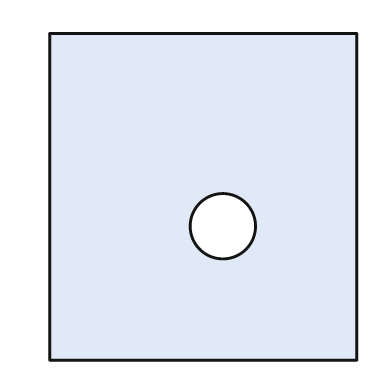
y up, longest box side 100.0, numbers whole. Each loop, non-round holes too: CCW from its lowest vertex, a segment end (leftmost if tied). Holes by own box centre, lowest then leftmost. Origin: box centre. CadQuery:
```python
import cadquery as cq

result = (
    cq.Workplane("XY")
    .moveTo(-47.0, -50.0)
    .lineTo(47.0, -50.0)
    .lineTo(47.0, 50.0)
    .lineTo(-47.0, 50.0)
    .close()
    .moveTo(6.0, -9.0)
    .circle(10.0)
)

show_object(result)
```